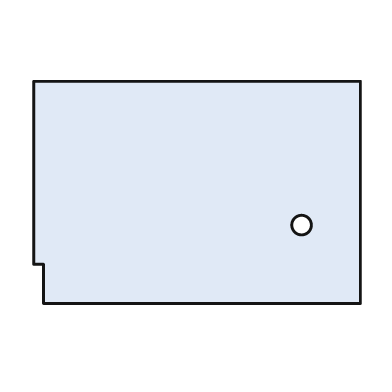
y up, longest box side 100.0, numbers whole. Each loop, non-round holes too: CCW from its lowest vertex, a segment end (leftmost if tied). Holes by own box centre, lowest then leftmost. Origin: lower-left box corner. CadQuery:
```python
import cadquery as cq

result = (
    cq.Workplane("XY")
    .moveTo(3.0, 0.0)
    .lineTo(100.0, 0.0)
    .lineTo(100.0, 68.0)
    .lineTo(0.0, 68.0)
    .lineTo(0.0, 12.0)
    .lineTo(3.0, 12.0)
    .close()
    .moveTo(82.0, 24.0)
    .circle(3.0)
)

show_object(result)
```